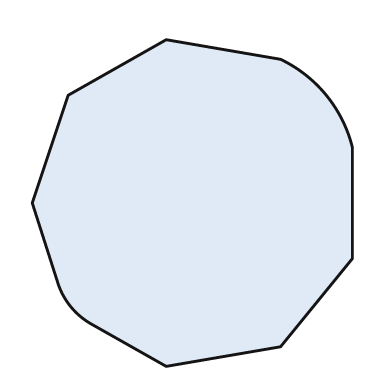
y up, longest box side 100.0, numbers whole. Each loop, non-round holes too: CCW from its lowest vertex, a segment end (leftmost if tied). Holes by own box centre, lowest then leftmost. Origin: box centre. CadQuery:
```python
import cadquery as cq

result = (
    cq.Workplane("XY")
    .moveTo(-8.0, -50.0)
    .lineTo(27.0, -44.0)
    .lineTo(49.0, -17.0)
    .lineTo(49.0, 17.0)
    .threePointArc((41.0, 33.0), (27.0, 44.0))
    .lineTo(-8.0, 50.0)
    .lineTo(-38.0, 33.0)
    .lineTo(-49.0, 0.0)
    .lineTo(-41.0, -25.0)
    .threePointArc((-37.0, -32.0), (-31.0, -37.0))
    .close()
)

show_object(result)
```